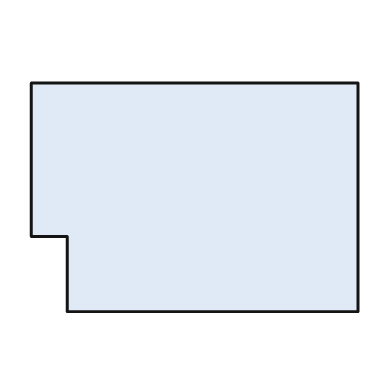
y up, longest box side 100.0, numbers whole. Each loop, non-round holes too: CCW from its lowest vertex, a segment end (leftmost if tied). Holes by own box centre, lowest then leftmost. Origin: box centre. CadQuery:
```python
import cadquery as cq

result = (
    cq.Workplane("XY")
    .moveTo(-39.0, -35.0)
    .lineTo(50.0, -35.0)
    .lineTo(50.0, 35.0)
    .lineTo(-50.0, 35.0)
    .lineTo(-50.0, -12.0)
    .lineTo(-39.0, -12.0)
    .close()
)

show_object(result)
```